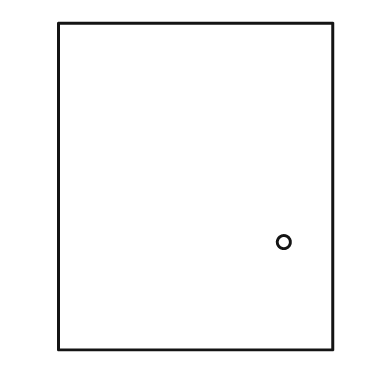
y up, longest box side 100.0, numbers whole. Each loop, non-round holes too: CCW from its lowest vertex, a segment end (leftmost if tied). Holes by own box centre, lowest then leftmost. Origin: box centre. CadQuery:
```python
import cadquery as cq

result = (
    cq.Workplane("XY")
    .moveTo(-42.0, -50.0)
    .lineTo(42.0, -50.0)
    .lineTo(42.0, 50.0)
    .lineTo(-42.0, 50.0)
    .close()
    .moveTo(27.0, -17.0)
    .circle(2.0)
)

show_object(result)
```